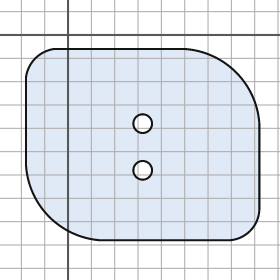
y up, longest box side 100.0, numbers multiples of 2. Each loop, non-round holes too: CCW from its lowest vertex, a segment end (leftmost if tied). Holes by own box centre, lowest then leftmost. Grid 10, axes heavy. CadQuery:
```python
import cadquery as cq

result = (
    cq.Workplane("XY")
    .moveTo(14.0, -88.0)
    .lineTo(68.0, -88.0)
    .threePointArc((78.0, -84.0), (82.0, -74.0))
    .lineTo(82.0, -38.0)
    .threePointArc((72.0, -16.0), (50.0, -6.0))
    .lineTo(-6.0, -6.0)
    .threePointArc((-14.0, -10.0), (-18.0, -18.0))
    .lineTo(-18.0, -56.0)
    .threePointArc((-8.0, -78.0), (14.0, -88.0))
    .close()
    .moveTo(32.0, -58.0)
    .circle(4.0)
    .moveTo(32.0, -38.0)
    .circle(4.0)
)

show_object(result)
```